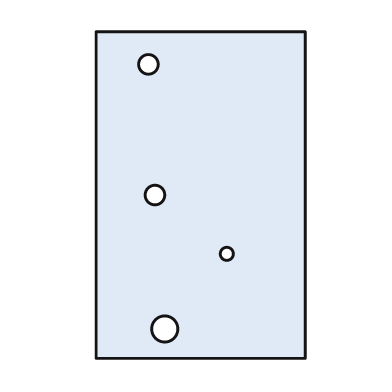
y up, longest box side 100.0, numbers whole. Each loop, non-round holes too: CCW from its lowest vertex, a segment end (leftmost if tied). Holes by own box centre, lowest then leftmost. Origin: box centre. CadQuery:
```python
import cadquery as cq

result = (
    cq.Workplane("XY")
    .moveTo(-32.0, -50.0)
    .lineTo(32.0, -50.0)
    .lineTo(32.0, 50.0)
    .lineTo(-32.0, 50.0)
    .close()
    .moveTo(-11.0, -41.0)
    .circle(4.0)
    .moveTo(8.0, -18.0)
    .circle(2.0)
    .moveTo(-14.0, 0.0)
    .circle(3.0)
    .moveTo(-16.0, 40.0)
    .circle(3.0)
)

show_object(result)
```